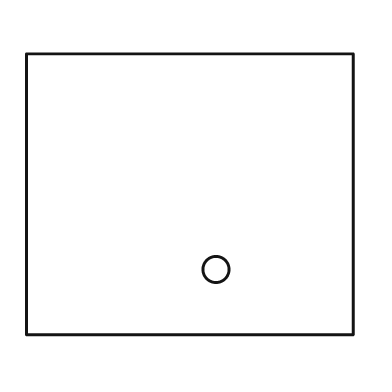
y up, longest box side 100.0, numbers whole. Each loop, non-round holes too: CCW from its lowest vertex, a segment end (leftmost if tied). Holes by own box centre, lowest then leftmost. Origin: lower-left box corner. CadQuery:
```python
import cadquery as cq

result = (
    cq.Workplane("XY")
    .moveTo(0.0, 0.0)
    .lineTo(100.0, 0.0)
    .lineTo(100.0, 86.0)
    .lineTo(0.0, 86.0)
    .close()
    .moveTo(58.0, 20.0)
    .circle(4.0)
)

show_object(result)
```